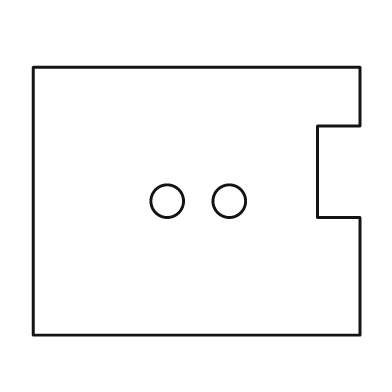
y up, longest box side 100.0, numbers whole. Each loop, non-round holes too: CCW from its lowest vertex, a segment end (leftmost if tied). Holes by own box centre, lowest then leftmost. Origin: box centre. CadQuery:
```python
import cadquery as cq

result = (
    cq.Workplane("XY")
    .moveTo(-50.0, -41.0)
    .lineTo(50.0, -41.0)
    .lineTo(50.0, -5.0)
    .lineTo(37.0, -5.0)
    .lineTo(37.0, 23.0)
    .lineTo(50.0, 23.0)
    .lineTo(50.0, 41.0)
    .lineTo(-50.0, 41.0)
    .close()
    .moveTo(-9.0, 0.0)
    .circle(5.0)
    .moveTo(10.0, 0.0)
    .circle(5.0)
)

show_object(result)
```